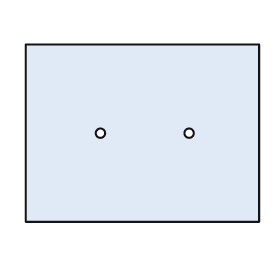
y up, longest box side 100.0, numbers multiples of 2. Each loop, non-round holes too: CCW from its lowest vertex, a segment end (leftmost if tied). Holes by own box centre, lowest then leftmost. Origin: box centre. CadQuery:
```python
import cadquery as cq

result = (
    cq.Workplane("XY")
    .moveTo(-50.0, -38.0)
    .lineTo(50.0, -38.0)
    .lineTo(50.0, 38.0)
    .lineTo(-50.0, 38.0)
    .close()
    .moveTo(-18.0, 0.0)
    .circle(2.0)
    .moveTo(20.0, 0.0)
    .circle(2.0)
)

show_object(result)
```